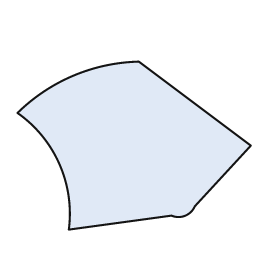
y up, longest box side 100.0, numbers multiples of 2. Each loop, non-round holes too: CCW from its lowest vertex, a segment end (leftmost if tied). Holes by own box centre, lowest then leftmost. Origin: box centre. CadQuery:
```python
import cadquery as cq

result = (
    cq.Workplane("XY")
    .moveTo(-28.0, -36.0)
    .lineTo(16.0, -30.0)
    .threePointArc((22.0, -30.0), (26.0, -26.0))
    .lineTo(50.0, 0.0)
    .lineTo(2.0, 36.0)
    .threePointArc((-26.0, 30.0), (-50.0, 14.0))
    .threePointArc((-32.0, -8.0), (-28.0, -36.0))
    .close()
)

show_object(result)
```